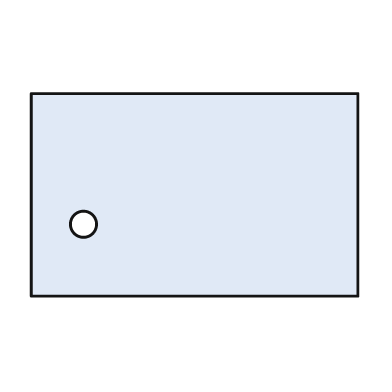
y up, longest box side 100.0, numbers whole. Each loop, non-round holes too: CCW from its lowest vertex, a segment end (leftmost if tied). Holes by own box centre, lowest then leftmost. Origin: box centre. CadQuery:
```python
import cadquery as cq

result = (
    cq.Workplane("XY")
    .moveTo(-50.0, -31.0)
    .lineTo(50.0, -31.0)
    .lineTo(50.0, 31.0)
    .lineTo(-50.0, 31.0)
    .close()
    .moveTo(-34.0, -9.0)
    .circle(4.0)
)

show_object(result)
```